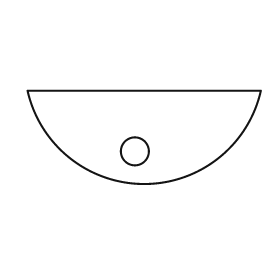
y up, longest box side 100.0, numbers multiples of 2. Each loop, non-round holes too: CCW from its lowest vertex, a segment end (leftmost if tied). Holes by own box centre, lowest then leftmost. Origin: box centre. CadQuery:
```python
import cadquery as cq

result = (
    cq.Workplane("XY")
    .moveTo(-50.0, 20.0)
    .threePointArc((0.0, -20.0), (50.0, 20.0))
    .close()
    .moveTo(-4.0, -6.0)
    .circle(6.0)
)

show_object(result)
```